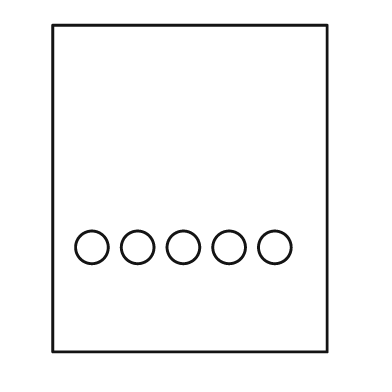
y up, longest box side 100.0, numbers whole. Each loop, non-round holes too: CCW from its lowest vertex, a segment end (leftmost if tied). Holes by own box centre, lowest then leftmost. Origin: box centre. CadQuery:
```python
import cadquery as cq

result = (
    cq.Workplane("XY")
    .moveTo(-42.0, -50.0)
    .lineTo(42.0, -50.0)
    .lineTo(42.0, 50.0)
    .lineTo(-42.0, 50.0)
    .close()
    .moveTo(-30.0, -18.0)
    .circle(5.0)
    .moveTo(-16.0, -18.0)
    .circle(5.0)
    .moveTo(-2.0, -18.0)
    .circle(5.0)
    .moveTo(12.0, -18.0)
    .circle(5.0)
    .moveTo(26.0, -18.0)
    .circle(5.0)
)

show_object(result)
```